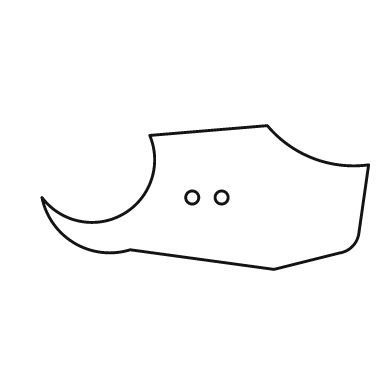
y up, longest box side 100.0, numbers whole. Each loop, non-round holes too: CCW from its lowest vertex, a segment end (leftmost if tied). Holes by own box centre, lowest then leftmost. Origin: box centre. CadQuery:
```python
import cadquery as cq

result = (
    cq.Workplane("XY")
    .moveTo(21.0, -22.0)
    .lineTo(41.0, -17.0)
    .threePointArc((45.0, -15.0), (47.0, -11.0))
    .lineTo(50.0, 10.0)
    .threePointArc((33.0, 12.0), (19.0, 22.0))
    .lineTo(-17.0, 19.0)
    .threePointArc((-25.0, -5.0), (-50.0, 0.0))
    .threePointArc((-40.0, -14.0), (-23.0, -16.0))
    .close()
    .moveTo(-4.0, 0.0)
    .circle(2.0)
    .moveTo(5.0, 0.0)
    .circle(2.0)
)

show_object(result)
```